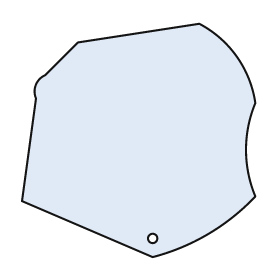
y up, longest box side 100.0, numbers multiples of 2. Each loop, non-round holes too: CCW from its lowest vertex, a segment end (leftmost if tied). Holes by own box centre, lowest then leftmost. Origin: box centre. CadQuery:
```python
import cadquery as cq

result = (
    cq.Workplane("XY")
    .moveTo(6.0, -50.0)
    .threePointArc((30.0, -40.0), (50.0, -24.0))
    .threePointArc((46.0, -4.0), (50.0, 16.0))
    .threePointArc((42.0, 36.0), (26.0, 50.0))
    .lineTo(-26.0, 42.0)
    .lineTo(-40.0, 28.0)
    .threePointArc((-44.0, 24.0), (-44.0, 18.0))
    .lineTo(-50.0, -26.0)
    .close()
    .moveTo(6.0, -42.0)
    .circle(2.0)
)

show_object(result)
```